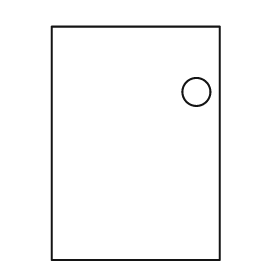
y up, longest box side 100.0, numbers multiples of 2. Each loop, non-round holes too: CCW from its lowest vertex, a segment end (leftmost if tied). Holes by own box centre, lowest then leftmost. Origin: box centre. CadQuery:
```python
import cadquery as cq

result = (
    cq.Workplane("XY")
    .moveTo(-36.0, -50.0)
    .lineTo(36.0, -50.0)
    .lineTo(36.0, 50.0)
    .lineTo(-36.0, 50.0)
    .close()
    .moveTo(26.0, 22.0)
    .circle(6.0)
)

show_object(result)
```